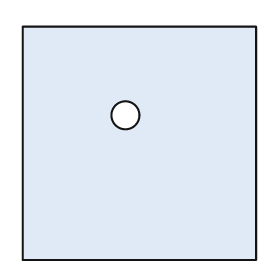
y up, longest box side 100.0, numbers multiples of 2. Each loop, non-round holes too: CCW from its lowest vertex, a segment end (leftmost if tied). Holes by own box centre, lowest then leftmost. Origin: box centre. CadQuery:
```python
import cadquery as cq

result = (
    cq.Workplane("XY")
    .moveTo(-50.0, -50.0)
    .lineTo(50.0, -50.0)
    .lineTo(50.0, 50.0)
    .lineTo(-50.0, 50.0)
    .close()
    .moveTo(-6.0, 12.0)
    .circle(6.0)
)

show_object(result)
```